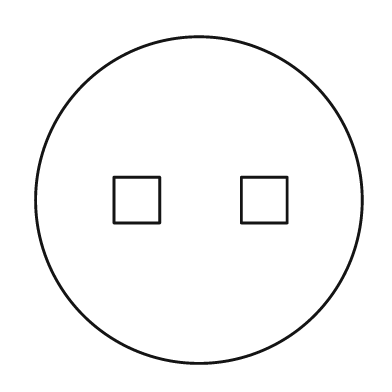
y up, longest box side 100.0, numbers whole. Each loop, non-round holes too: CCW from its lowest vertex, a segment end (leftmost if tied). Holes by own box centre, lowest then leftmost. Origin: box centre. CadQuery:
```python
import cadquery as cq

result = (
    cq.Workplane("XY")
    .moveTo(0.0, 0.0)
    .circle(50.0)
    .moveTo(-26.0, -7.0)
    .lineTo(-12.0, -7.0)
    .lineTo(-12.0, 7.0)
    .lineTo(-26.0, 7.0)
    .close()
    .moveTo(13.0, -7.0)
    .lineTo(27.0, -7.0)
    .lineTo(27.0, 7.0)
    .lineTo(13.0, 7.0)
    .close()
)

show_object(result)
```